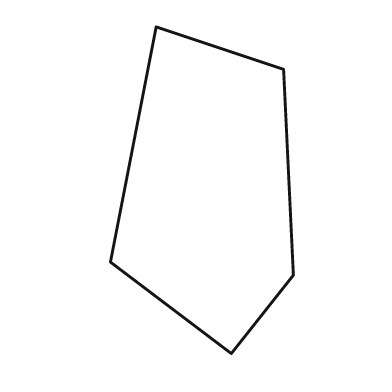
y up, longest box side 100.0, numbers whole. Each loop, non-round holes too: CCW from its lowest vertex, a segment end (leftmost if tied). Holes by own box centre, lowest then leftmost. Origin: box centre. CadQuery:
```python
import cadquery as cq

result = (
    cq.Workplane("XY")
    .moveTo(9.0, -50.0)
    .lineTo(28.0, -26.0)
    .lineTo(25.0, 37.0)
    .lineTo(-14.0, 50.0)
    .lineTo(-28.0, -22.0)
    .close()
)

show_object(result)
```